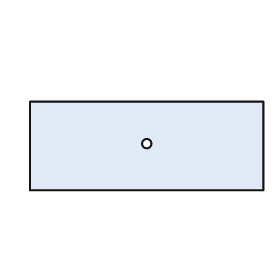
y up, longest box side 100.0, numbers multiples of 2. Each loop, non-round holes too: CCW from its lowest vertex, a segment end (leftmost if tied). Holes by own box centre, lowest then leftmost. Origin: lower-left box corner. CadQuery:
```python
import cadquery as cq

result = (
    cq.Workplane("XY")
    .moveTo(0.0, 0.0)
    .lineTo(100.0, 0.0)
    .lineTo(100.0, 38.0)
    .lineTo(0.0, 38.0)
    .close()
    .moveTo(50.0, 20.0)
    .circle(2.0)
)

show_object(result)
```